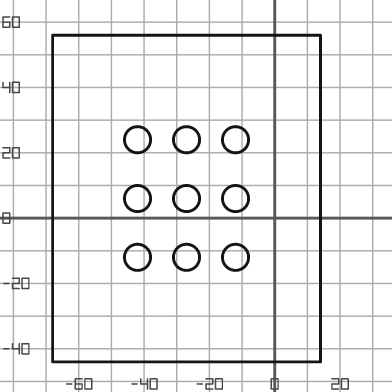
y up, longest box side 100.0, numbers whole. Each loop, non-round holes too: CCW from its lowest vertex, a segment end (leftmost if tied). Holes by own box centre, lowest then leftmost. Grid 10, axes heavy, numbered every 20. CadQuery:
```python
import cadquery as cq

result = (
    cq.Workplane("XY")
    .moveTo(-68.0, -44.0)
    .lineTo(14.0, -44.0)
    .lineTo(14.0, 56.0)
    .lineTo(-68.0, 56.0)
    .close()
    .moveTo(-42.0, -12.0)
    .circle(4.0)
    .moveTo(-27.0, -12.0)
    .circle(4.0)
    .moveTo(-12.0, -12.0)
    .circle(4.0)
    .moveTo(-42.0, 6.0)
    .circle(4.0)
    .moveTo(-27.0, 6.0)
    .circle(4.0)
    .moveTo(-12.0, 6.0)
    .circle(4.0)
    .moveTo(-42.0, 24.0)
    .circle(4.0)
    .moveTo(-27.0, 24.0)
    .circle(4.0)
    .moveTo(-12.0, 24.0)
    .circle(4.0)
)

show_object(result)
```